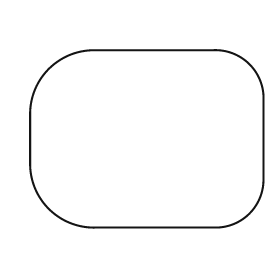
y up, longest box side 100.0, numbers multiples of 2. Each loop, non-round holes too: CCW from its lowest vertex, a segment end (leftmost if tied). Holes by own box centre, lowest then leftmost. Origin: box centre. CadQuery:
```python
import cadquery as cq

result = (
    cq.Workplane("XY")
    .moveTo(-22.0, -38.0)
    .lineTo(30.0, -38.0)
    .threePointArc((44.0, -32.0), (50.0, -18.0))
    .lineTo(50.0, 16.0)
    .threePointArc((44.0, 32.0), (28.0, 38.0))
    .lineTo(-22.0, 38.0)
    .threePointArc((-42.0, 30.0), (-50.0, 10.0))
    .lineTo(-50.0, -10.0)
    .threePointArc((-42.0, -30.0), (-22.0, -38.0))
    .close()
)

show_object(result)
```